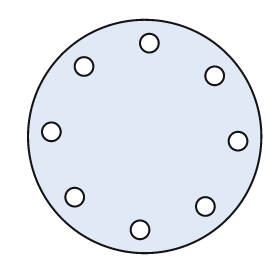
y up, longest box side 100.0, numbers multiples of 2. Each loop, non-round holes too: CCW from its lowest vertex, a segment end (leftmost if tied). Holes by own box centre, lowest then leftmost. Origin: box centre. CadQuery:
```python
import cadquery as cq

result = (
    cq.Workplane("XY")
    .moveTo(0.0, 0.0)
    .circle(50.0)
    .moveTo(-2.0, -40.0)
    .circle(4.0)
    .moveTo(26.0, -30.0)
    .circle(4.0)
    .moveTo(-30.0, -26.0)
    .circle(4.0)
    .moveTo(40.0, -2.0)
    .circle(4.0)
    .moveTo(-40.0, 2.0)
    .circle(4.0)
    .moveTo(30.0, 26.0)
    .circle(4.0)
    .moveTo(-26.0, 30.0)
    .circle(4.0)
    .moveTo(2.0, 40.0)
    .circle(4.0)
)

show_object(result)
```